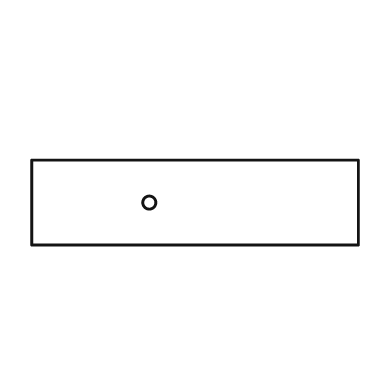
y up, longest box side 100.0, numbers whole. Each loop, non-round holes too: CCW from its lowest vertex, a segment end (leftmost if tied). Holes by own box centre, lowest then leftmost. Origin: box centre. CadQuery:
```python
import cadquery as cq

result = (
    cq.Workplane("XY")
    .moveTo(-50.0, -13.0)
    .lineTo(50.0, -13.0)
    .lineTo(50.0, 13.0)
    .lineTo(-50.0, 13.0)
    .close()
    .moveTo(-14.0, 0.0)
    .circle(2.0)
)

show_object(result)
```